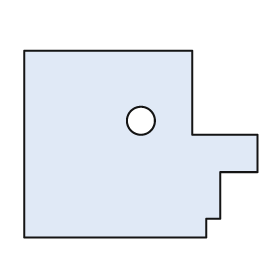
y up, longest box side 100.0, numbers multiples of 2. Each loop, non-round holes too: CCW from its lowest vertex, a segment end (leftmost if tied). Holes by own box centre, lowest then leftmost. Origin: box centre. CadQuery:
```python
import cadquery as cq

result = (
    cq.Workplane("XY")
    .moveTo(-50.0, -40.0)
    .lineTo(28.0, -40.0)
    .lineTo(28.0, -32.0)
    .lineTo(34.0, -32.0)
    .lineTo(34.0, -12.0)
    .lineTo(50.0, -12.0)
    .lineTo(50.0, 4.0)
    .lineTo(22.0, 4.0)
    .lineTo(22.0, 40.0)
    .lineTo(-50.0, 40.0)
    .close()
    .moveTo(0.0, 10.0)
    .circle(6.0)
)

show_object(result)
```